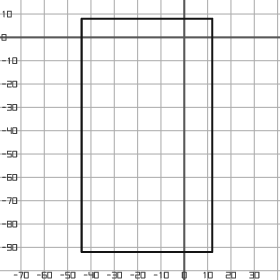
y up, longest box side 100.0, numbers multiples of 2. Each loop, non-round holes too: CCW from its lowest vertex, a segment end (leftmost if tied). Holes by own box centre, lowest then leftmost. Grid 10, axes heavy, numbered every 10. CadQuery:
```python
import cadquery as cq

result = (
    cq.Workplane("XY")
    .moveTo(-44.0, -92.0)
    .lineTo(12.0, -92.0)
    .lineTo(12.0, 8.0)
    .lineTo(-44.0, 8.0)
    .close()
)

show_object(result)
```